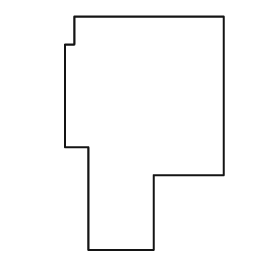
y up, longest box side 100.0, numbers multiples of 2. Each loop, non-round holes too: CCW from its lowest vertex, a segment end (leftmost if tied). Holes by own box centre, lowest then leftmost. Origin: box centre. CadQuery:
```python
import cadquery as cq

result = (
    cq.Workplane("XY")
    .moveTo(-24.0, -50.0)
    .lineTo(4.0, -50.0)
    .lineTo(4.0, -18.0)
    .lineTo(34.0, -18.0)
    .lineTo(34.0, 50.0)
    .lineTo(-30.0, 50.0)
    .lineTo(-30.0, 38.0)
    .lineTo(-34.0, 38.0)
    .lineTo(-34.0, -6.0)
    .lineTo(-24.0, -6.0)
    .close()
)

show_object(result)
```